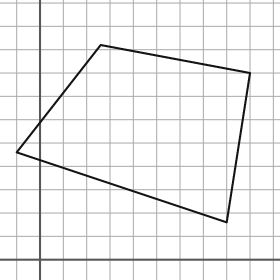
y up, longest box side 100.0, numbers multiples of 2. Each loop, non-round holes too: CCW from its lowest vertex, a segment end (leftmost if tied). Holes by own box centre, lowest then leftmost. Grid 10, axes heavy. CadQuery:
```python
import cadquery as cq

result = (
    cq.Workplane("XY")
    .moveTo(80.0, 16.0)
    .lineTo(90.0, 80.0)
    .lineTo(26.0, 92.0)
    .lineTo(-10.0, 46.0)
    .close()
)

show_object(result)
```